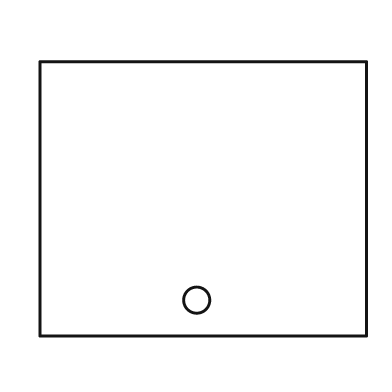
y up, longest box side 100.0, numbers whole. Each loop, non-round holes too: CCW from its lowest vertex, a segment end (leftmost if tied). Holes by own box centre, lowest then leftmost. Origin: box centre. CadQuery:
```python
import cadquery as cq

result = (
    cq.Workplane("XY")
    .moveTo(-50.0, -42.0)
    .lineTo(50.0, -42.0)
    .lineTo(50.0, 42.0)
    .lineTo(-50.0, 42.0)
    .close()
    .moveTo(-2.0, -31.0)
    .circle(4.0)
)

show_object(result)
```